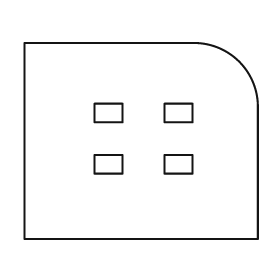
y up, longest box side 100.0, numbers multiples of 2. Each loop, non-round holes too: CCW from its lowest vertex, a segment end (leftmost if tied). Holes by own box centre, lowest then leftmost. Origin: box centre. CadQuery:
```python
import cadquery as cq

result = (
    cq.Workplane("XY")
    .moveTo(-50.0, -42.0)
    .lineTo(50.0, -42.0)
    .lineTo(50.0, 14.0)
    .threePointArc((42.0, 34.0), (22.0, 42.0))
    .lineTo(-50.0, 42.0)
    .close()
    .moveTo(-20.0, -14.0)
    .lineTo(-8.0, -14.0)
    .lineTo(-8.0, -6.0)
    .lineTo(-20.0, -6.0)
    .close()
    .moveTo(10.0, -14.0)
    .lineTo(22.0, -14.0)
    .lineTo(22.0, -6.0)
    .lineTo(10.0, -6.0)
    .close()
    .moveTo(-20.0, 8.0)
    .lineTo(-8.0, 8.0)
    .lineTo(-8.0, 16.0)
    .lineTo(-20.0, 16.0)
    .close()
    .moveTo(10.0, 8.0)
    .lineTo(22.0, 8.0)
    .lineTo(22.0, 16.0)
    .lineTo(10.0, 16.0)
    .close()
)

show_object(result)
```